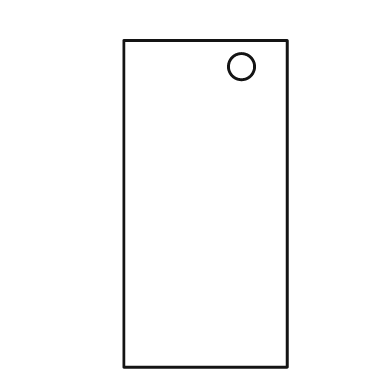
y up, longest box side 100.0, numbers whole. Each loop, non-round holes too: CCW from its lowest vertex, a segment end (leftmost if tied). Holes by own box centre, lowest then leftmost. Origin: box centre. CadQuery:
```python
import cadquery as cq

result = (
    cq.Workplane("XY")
    .moveTo(-25.0, -50.0)
    .lineTo(25.0, -50.0)
    .lineTo(25.0, 50.0)
    .lineTo(-25.0, 50.0)
    .close()
    .moveTo(11.0, 42.0)
    .circle(4.0)
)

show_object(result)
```